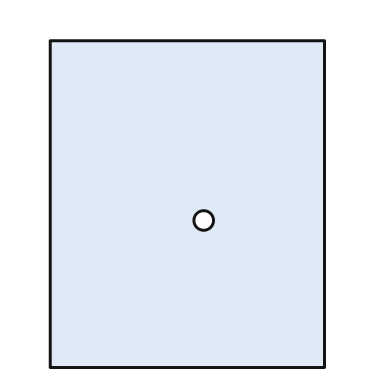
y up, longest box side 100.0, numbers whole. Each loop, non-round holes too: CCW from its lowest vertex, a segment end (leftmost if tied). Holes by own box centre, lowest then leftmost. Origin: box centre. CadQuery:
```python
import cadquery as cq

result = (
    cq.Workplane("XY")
    .moveTo(-42.0, -50.0)
    .lineTo(42.0, -50.0)
    .lineTo(42.0, 50.0)
    .lineTo(-42.0, 50.0)
    .close()
    .moveTo(5.0, -5.0)
    .circle(3.0)
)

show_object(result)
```